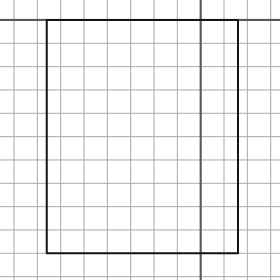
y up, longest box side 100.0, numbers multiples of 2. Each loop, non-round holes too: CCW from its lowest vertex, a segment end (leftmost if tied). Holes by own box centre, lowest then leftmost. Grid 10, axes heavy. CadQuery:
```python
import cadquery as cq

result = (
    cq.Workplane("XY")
    .moveTo(-66.0, -100.0)
    .lineTo(16.0, -100.0)
    .lineTo(16.0, 0.0)
    .lineTo(-66.0, 0.0)
    .close()
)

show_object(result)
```